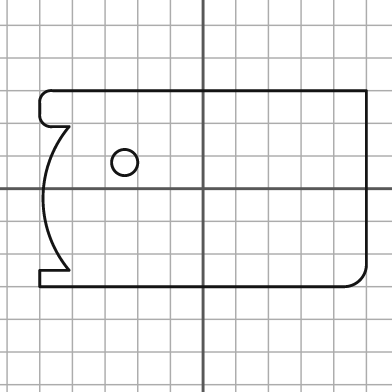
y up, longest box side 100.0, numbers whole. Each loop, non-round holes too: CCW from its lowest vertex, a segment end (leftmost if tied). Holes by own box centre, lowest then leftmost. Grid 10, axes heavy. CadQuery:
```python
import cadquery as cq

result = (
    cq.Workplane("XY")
    .moveTo(-50.0, -30.0)
    .lineTo(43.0, -30.0)
    .threePointArc((48.0, -28.0), (50.0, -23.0))
    .lineTo(50.0, 30.0)
    .lineTo(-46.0, 30.0)
    .threePointArc((-49.0, 29.0), (-50.0, 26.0))
    .lineTo(-50.0, 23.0)
    .threePointArc((-49.0, 20.0), (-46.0, 19.0))
    .lineTo(-41.0, 19.0)
    .threePointArc((-49.0, -3.0), (-41.0, -25.0))
    .lineTo(-50.0, -25.0)
    .close()
    .moveTo(-24.0, 8.0)
    .circle(4.0)
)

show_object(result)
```